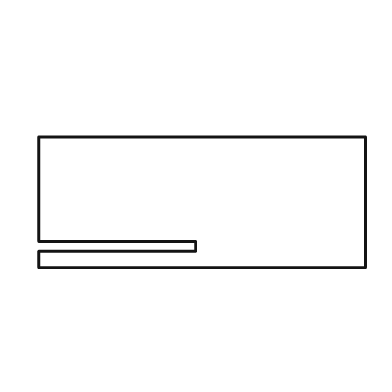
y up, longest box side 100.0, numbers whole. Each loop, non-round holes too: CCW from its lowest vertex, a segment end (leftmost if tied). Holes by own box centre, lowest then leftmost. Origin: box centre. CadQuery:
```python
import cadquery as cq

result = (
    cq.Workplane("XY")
    .moveTo(-50.0, -20.0)
    .lineTo(50.0, -20.0)
    .lineTo(50.0, 20.0)
    .lineTo(-50.0, 20.0)
    .lineTo(-50.0, -12.0)
    .lineTo(-2.0, -12.0)
    .lineTo(-2.0, -15.0)
    .lineTo(-50.0, -15.0)
    .close()
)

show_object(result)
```